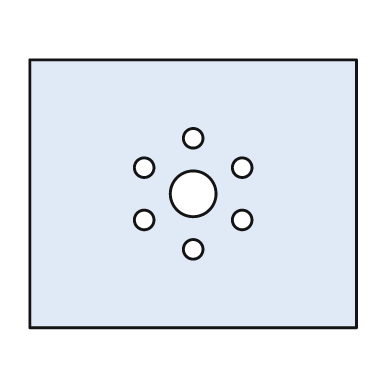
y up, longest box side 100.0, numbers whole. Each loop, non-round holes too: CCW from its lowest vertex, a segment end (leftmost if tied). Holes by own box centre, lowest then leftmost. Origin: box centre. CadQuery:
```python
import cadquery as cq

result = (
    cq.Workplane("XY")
    .moveTo(-50.0, -41.0)
    .lineTo(50.0, -41.0)
    .lineTo(50.0, 41.0)
    .lineTo(-50.0, 41.0)
    .close()
    .moveTo(0.0, -17.0)
    .circle(3.0)
    .moveTo(-15.0, -8.0)
    .circle(3.0)
    .moveTo(15.0, -8.0)
    .circle(3.0)
    .moveTo(0.0, 0.0)
    .circle(7.0)
    .moveTo(-15.0, 8.0)
    .circle(3.0)
    .moveTo(15.0, 8.0)
    .circle(3.0)
    .moveTo(0.0, 17.0)
    .circle(3.0)
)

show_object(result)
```